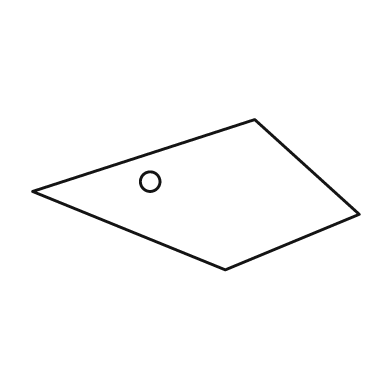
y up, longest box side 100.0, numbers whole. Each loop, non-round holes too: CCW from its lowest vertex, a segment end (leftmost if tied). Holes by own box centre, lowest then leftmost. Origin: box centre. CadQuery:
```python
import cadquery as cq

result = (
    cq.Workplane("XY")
    .moveTo(9.0, -23.0)
    .lineTo(50.0, -6.0)
    .lineTo(18.0, 23.0)
    .lineTo(-50.0, 1.0)
    .close()
    .moveTo(-14.0, 4.0)
    .circle(3.0)
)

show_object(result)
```